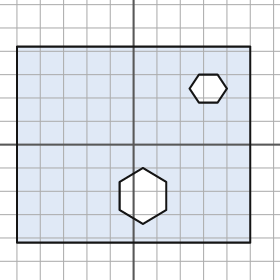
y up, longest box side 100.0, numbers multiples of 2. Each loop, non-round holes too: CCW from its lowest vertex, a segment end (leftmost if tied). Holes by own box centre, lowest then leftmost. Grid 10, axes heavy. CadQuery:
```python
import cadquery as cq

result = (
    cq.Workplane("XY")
    .moveTo(-50.0, -42.0)
    .lineTo(50.0, -42.0)
    .lineTo(50.0, 42.0)
    .lineTo(-50.0, 42.0)
    .close()
    .moveTo(4.0, -34.0)
    .lineTo(14.0, -28.0)
    .lineTo(14.0, -16.0)
    .lineTo(4.0, -10.0)
    .lineTo(-6.0, -16.0)
    .lineTo(-6.0, -28.0)
    .close()
    .moveTo(28.0, 18.0)
    .lineTo(36.0, 18.0)
    .lineTo(40.0, 24.0)
    .lineTo(36.0, 30.0)
    .lineTo(28.0, 30.0)
    .lineTo(24.0, 24.0)
    .close()
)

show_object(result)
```